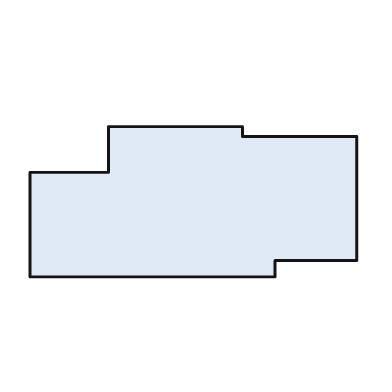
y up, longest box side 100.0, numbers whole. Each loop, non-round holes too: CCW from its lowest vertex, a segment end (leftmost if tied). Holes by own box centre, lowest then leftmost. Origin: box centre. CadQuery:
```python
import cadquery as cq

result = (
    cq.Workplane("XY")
    .moveTo(-50.0, -23.0)
    .lineTo(25.0, -23.0)
    .lineTo(25.0, -18.0)
    .lineTo(50.0, -18.0)
    .lineTo(50.0, 20.0)
    .lineTo(15.0, 20.0)
    .lineTo(15.0, 23.0)
    .lineTo(-26.0, 23.0)
    .lineTo(-26.0, 9.0)
    .lineTo(-50.0, 9.0)
    .close()
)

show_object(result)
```